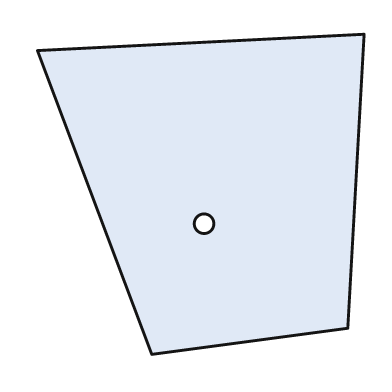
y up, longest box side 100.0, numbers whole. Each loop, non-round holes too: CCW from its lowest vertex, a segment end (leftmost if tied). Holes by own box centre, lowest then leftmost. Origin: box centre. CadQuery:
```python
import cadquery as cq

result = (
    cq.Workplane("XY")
    .moveTo(-15.0, -49.0)
    .lineTo(45.0, -41.0)
    .lineTo(50.0, 49.0)
    .lineTo(-50.0, 44.0)
    .close()
    .moveTo(1.0, -9.0)
    .circle(3.0)
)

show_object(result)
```